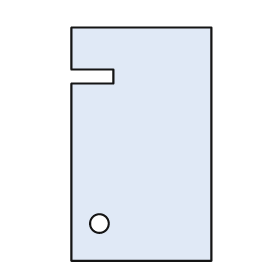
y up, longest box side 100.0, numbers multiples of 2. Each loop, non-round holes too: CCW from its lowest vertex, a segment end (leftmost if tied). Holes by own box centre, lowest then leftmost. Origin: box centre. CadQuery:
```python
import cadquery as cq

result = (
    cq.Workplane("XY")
    .moveTo(-30.0, -50.0)
    .lineTo(30.0, -50.0)
    .lineTo(30.0, 50.0)
    .lineTo(-30.0, 50.0)
    .lineTo(-30.0, 32.0)
    .lineTo(-12.0, 32.0)
    .lineTo(-12.0, 26.0)
    .lineTo(-30.0, 26.0)
    .close()
    .moveTo(-18.0, -34.0)
    .circle(4.0)
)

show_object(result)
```